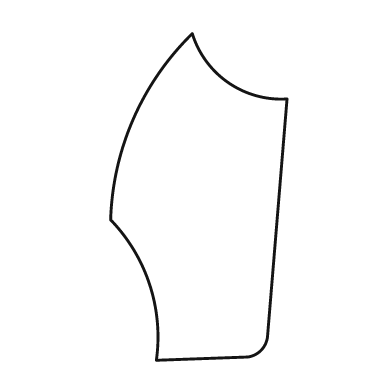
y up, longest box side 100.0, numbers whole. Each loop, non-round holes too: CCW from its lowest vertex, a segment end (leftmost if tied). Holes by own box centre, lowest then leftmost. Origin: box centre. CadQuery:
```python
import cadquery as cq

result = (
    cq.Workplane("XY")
    .moveTo(-13.0, -50.0)
    .lineTo(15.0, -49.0)
    .threePointArc((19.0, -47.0), (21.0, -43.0))
    .lineTo(27.0, 30.0)
    .threePointArc((9.0, 35.0), (-2.0, 50.0))
    .threePointArc((-20.0, 24.0), (-27.0, -7.0))
    .threePointArc((-15.0, -27.0), (-13.0, -50.0))
    .close()
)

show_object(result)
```